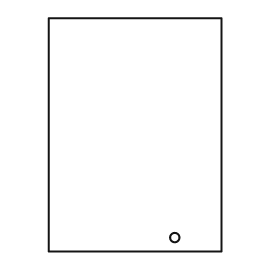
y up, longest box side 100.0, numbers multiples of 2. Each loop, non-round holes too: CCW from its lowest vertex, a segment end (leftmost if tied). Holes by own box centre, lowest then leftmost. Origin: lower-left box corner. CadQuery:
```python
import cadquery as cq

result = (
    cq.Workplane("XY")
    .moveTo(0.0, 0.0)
    .lineTo(74.0, 0.0)
    .lineTo(74.0, 100.0)
    .lineTo(0.0, 100.0)
    .close()
    .moveTo(54.0, 6.0)
    .circle(2.0)
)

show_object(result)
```